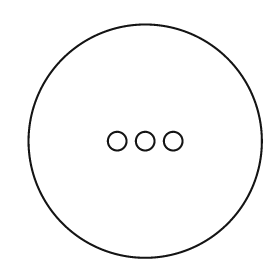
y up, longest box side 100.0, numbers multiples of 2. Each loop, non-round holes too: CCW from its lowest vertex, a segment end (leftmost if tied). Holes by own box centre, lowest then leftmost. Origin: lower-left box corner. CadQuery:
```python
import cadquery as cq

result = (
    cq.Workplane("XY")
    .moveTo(50.0, 50.0)
    .circle(50.0)
    .moveTo(38.0, 50.0)
    .circle(4.0)
    .moveTo(50.0, 50.0)
    .circle(4.0)
    .moveTo(62.0, 50.0)
    .circle(4.0)
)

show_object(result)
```